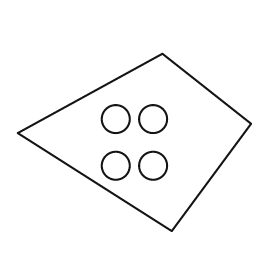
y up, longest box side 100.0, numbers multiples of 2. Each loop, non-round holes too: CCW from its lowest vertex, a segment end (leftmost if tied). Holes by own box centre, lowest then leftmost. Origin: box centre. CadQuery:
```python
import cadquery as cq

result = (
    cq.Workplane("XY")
    .moveTo(16.0, -38.0)
    .lineTo(50.0, 8.0)
    .lineTo(12.0, 38.0)
    .lineTo(-50.0, 4.0)
    .close()
    .moveTo(-8.0, -10.0)
    .circle(6.0)
    .moveTo(8.0, -10.0)
    .circle(6.0)
    .moveTo(-8.0, 10.0)
    .circle(6.0)
    .moveTo(8.0, 10.0)
    .circle(6.0)
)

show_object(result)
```